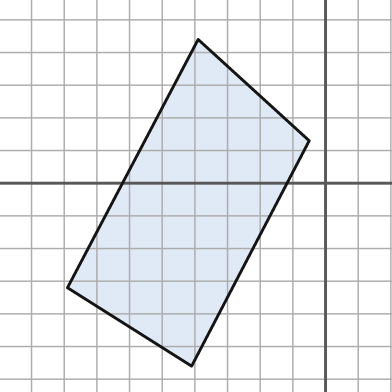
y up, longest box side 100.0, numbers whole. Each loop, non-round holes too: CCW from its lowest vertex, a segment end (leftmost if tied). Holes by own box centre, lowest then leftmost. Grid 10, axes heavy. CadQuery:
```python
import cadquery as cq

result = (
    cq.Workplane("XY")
    .moveTo(-41.0, -56.0)
    .lineTo(-5.0, 13.0)
    .lineTo(-39.0, 44.0)
    .lineTo(-79.0, -32.0)
    .close()
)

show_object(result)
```